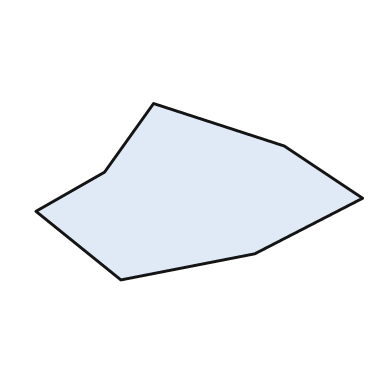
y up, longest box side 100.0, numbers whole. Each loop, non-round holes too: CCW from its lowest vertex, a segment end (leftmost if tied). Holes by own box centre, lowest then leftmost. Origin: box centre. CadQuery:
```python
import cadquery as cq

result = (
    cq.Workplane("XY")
    .moveTo(-24.0, -27.0)
    .lineTo(17.0, -19.0)
    .lineTo(50.0, -2.0)
    .lineTo(26.0, 14.0)
    .lineTo(-14.0, 27.0)
    .lineTo(-29.0, 6.0)
    .lineTo(-50.0, -6.0)
    .close()
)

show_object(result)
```